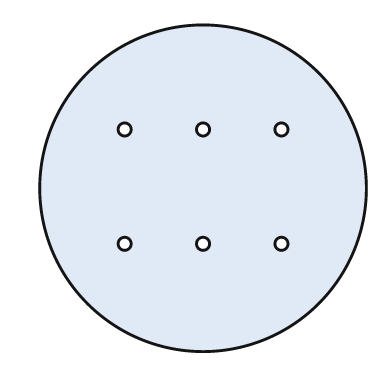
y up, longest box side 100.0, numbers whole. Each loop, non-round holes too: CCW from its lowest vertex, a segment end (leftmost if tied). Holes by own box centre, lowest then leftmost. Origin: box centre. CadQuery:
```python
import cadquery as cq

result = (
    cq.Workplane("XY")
    .moveTo(0.0, 0.0)
    .circle(50.0)
    .moveTo(-24.0, -17.0)
    .circle(2.0)
    .moveTo(0.0, -17.0)
    .circle(2.0)
    .moveTo(24.0, -17.0)
    .circle(2.0)
    .moveTo(-24.0, 18.0)
    .circle(2.0)
    .moveTo(0.0, 18.0)
    .circle(2.0)
    .moveTo(24.0, 18.0)
    .circle(2.0)
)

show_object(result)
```